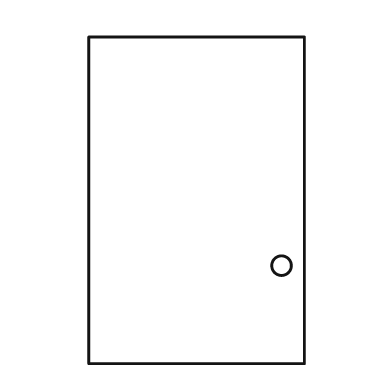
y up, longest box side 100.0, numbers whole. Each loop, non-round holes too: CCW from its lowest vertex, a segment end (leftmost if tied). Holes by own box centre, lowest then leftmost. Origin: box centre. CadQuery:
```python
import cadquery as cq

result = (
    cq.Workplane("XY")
    .moveTo(-33.0, -50.0)
    .lineTo(33.0, -50.0)
    .lineTo(33.0, 50.0)
    .lineTo(-33.0, 50.0)
    .close()
    .moveTo(26.0, -20.0)
    .circle(3.0)
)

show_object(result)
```